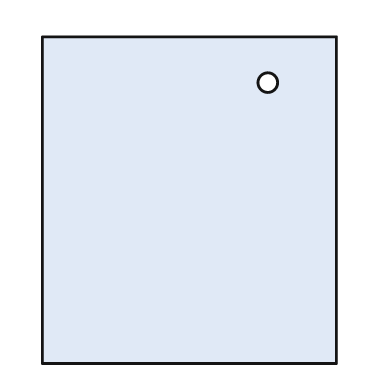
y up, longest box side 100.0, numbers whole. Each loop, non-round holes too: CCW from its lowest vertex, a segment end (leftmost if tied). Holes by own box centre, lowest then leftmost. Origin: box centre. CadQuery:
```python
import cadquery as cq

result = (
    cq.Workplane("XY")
    .moveTo(-45.0, -50.0)
    .lineTo(45.0, -50.0)
    .lineTo(45.0, 50.0)
    .lineTo(-45.0, 50.0)
    .close()
    .moveTo(24.0, 36.0)
    .circle(3.0)
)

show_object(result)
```